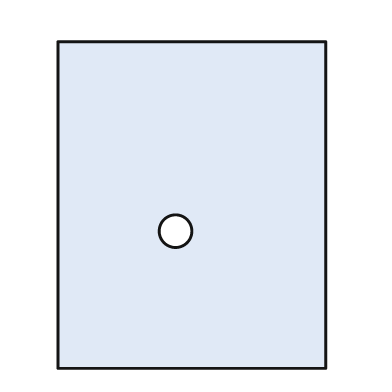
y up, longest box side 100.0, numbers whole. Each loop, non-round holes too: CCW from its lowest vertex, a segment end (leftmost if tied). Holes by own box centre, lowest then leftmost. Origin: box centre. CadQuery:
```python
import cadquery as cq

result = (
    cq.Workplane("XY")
    .moveTo(-41.0, -50.0)
    .lineTo(41.0, -50.0)
    .lineTo(41.0, 50.0)
    .lineTo(-41.0, 50.0)
    .close()
    .moveTo(-5.0, -8.0)
    .circle(5.0)
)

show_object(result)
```